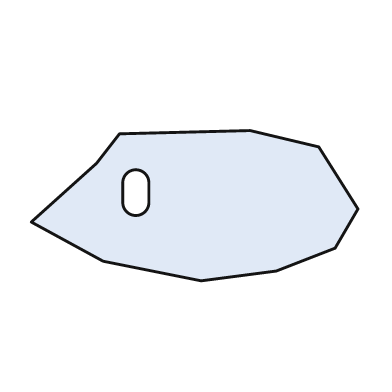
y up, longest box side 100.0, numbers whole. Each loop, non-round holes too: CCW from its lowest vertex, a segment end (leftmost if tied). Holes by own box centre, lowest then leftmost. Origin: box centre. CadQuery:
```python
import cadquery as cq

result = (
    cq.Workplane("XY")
    .moveTo(2.0, -23.0)
    .lineTo(25.0, -20.0)
    .lineTo(43.0, -13.0)
    .lineTo(50.0, -1.0)
    .lineTo(38.0, 18.0)
    .lineTo(17.0, 23.0)
    .lineTo(-23.0, 22.0)
    .lineTo(-30.0, 13.0)
    .lineTo(-50.0, -5.0)
    .lineTo(-28.0, -17.0)
    .close()
    .moveTo(-22.0, 1.0)
    .threePointArc((-18.0, -3.0), (-14.0, 1.0))
    .lineTo(-14.0, 7.0)
    .threePointArc((-18.0, 11.0), (-22.0, 7.0))
    .close()
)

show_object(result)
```